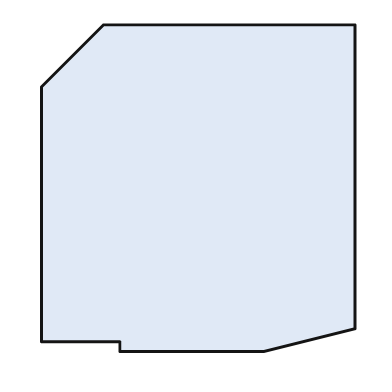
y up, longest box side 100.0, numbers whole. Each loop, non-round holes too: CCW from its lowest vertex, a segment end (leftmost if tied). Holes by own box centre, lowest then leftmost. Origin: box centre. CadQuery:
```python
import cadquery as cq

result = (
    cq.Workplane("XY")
    .moveTo(-24.0, -50.0)
    .lineTo(20.0, -50.0)
    .lineTo(48.0, -43.0)
    .lineTo(48.0, 50.0)
    .lineTo(-29.0, 50.0)
    .lineTo(-48.0, 31.0)
    .lineTo(-48.0, -47.0)
    .lineTo(-24.0, -47.0)
    .close()
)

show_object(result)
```